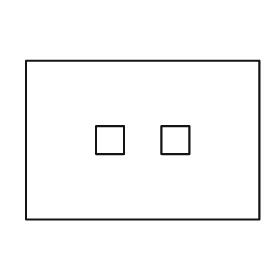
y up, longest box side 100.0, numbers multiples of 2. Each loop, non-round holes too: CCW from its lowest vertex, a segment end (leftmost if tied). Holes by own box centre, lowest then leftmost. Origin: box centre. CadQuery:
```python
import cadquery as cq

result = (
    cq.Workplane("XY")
    .moveTo(-50.0, -34.0)
    .lineTo(50.0, -34.0)
    .lineTo(50.0, 34.0)
    .lineTo(-50.0, 34.0)
    .close()
    .moveTo(-20.0, -6.0)
    .lineTo(-8.0, -6.0)
    .lineTo(-8.0, 6.0)
    .lineTo(-20.0, 6.0)
    .close()
    .moveTo(8.0, -6.0)
    .lineTo(20.0, -6.0)
    .lineTo(20.0, 6.0)
    .lineTo(8.0, 6.0)
    .close()
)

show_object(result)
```